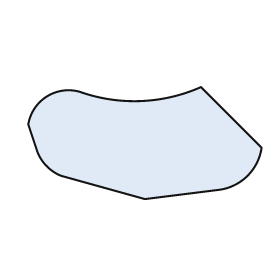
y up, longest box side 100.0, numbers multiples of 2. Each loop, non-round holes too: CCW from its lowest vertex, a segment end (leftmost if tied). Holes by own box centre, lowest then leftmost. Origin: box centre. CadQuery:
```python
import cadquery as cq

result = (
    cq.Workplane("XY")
    .moveTo(0.0, -24.0)
    .lineTo(32.0, -20.0)
    .threePointArc((44.0, -14.0), (50.0, -2.0))
    .lineTo(24.0, 24.0)
    .threePointArc((-2.0, 18.0), (-28.0, 22.0))
    .threePointArc((-42.0, 20.0), (-50.0, 8.0))
    .lineTo(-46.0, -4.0)
    .threePointArc((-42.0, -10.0), (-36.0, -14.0))
    .close()
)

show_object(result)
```